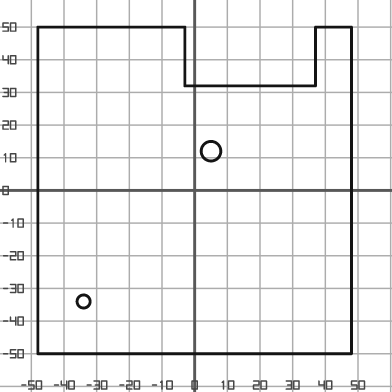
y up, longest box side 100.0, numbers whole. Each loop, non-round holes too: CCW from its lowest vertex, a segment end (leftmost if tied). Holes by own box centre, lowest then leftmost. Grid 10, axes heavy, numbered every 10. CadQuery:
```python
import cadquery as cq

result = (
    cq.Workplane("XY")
    .moveTo(-48.0, -50.0)
    .lineTo(48.0, -50.0)
    .lineTo(48.0, 50.0)
    .lineTo(37.0, 50.0)
    .lineTo(37.0, 32.0)
    .lineTo(-3.0, 32.0)
    .lineTo(-3.0, 50.0)
    .lineTo(-48.0, 50.0)
    .close()
    .moveTo(-34.0, -34.0)
    .circle(2.0)
    .moveTo(5.0, 12.0)
    .circle(3.0)
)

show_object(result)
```